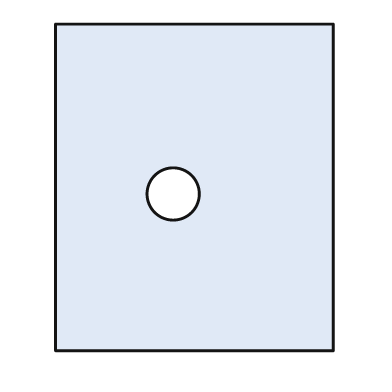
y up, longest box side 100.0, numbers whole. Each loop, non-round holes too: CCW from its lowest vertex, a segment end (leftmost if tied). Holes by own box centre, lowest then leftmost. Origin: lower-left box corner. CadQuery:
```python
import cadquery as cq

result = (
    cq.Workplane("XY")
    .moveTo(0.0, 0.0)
    .lineTo(85.0, 0.0)
    .lineTo(85.0, 100.0)
    .lineTo(0.0, 100.0)
    .close()
    .moveTo(36.0, 48.0)
    .circle(8.0)
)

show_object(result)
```